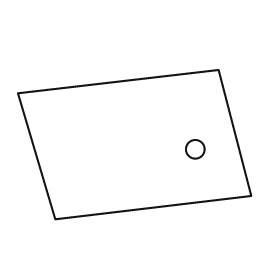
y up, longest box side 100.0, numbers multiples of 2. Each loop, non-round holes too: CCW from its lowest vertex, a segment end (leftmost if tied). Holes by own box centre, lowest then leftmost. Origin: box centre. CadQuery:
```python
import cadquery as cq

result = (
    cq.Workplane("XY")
    .moveTo(-34.0, -32.0)
    .lineTo(50.0, -22.0)
    .lineTo(36.0, 32.0)
    .lineTo(-50.0, 22.0)
    .close()
    .moveTo(26.0, -2.0)
    .circle(4.0)
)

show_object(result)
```